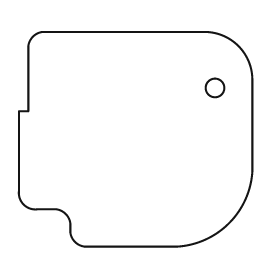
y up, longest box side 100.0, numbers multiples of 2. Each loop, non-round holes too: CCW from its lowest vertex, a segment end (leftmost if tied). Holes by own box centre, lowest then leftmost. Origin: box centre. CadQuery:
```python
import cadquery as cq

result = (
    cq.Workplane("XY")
    .moveTo(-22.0, -46.0)
    .lineTo(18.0, -46.0)
    .threePointArc((40.0, -36.0), (50.0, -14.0))
    .lineTo(50.0, 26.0)
    .threePointArc((44.0, 40.0), (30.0, 46.0))
    .lineTo(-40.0, 46.0)
    .threePointArc((-44.0, 44.0), (-46.0, 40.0))
    .lineTo(-46.0, 12.0)
    .lineTo(-50.0, 12.0)
    .lineTo(-50.0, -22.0)
    .threePointArc((-48.0, -28.0), (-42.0, -30.0))
    .lineTo(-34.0, -30.0)
    .threePointArc((-30.0, -32.0), (-28.0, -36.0))
    .lineTo(-28.0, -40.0)
    .threePointArc((-26.0, -44.0), (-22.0, -46.0))
    .close()
    .moveTo(34.0, 22.0)
    .circle(4.0)
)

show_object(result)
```